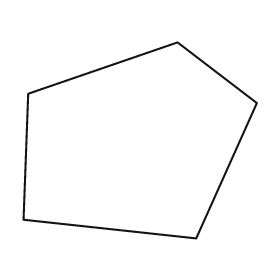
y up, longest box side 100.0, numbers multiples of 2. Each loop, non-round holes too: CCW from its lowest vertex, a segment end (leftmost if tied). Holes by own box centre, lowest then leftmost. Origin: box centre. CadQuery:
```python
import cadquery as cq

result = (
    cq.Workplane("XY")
    .moveTo(24.0, -42.0)
    .lineTo(50.0, 16.0)
    .lineTo(16.0, 42.0)
    .lineTo(-48.0, 20.0)
    .lineTo(-50.0, -34.0)
    .close()
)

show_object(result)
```